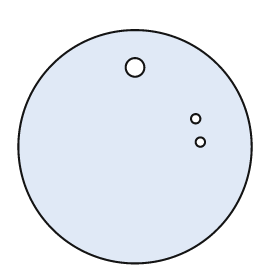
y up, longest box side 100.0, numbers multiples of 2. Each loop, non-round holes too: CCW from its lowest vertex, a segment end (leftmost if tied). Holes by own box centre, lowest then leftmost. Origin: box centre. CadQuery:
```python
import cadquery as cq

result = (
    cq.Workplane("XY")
    .moveTo(0.0, 0.0)
    .circle(50.0)
    .moveTo(28.0, 2.0)
    .circle(2.0)
    .moveTo(26.0, 12.0)
    .circle(2.0)
    .moveTo(0.0, 34.0)
    .circle(4.0)
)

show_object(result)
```